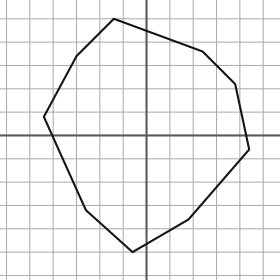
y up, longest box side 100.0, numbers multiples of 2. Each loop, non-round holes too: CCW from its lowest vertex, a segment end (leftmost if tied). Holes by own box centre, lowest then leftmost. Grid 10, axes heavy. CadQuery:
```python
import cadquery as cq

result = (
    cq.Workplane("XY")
    .moveTo(-6.0, -50.0)
    .lineTo(18.0, -36.0)
    .lineTo(44.0, -6.0)
    .lineTo(38.0, 22.0)
    .lineTo(24.0, 36.0)
    .lineTo(-14.0, 50.0)
    .lineTo(-30.0, 34.0)
    .lineTo(-44.0, 8.0)
    .lineTo(-26.0, -32.0)
    .close()
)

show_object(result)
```